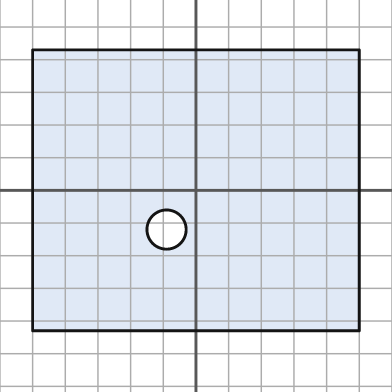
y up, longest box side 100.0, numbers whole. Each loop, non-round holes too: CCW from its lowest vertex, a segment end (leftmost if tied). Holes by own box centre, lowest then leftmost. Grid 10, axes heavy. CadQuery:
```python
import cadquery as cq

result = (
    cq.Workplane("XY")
    .moveTo(-50.0, -43.0)
    .lineTo(50.0, -43.0)
    .lineTo(50.0, 43.0)
    .lineTo(-50.0, 43.0)
    .close()
    .moveTo(-9.0, -12.0)
    .circle(6.0)
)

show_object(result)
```